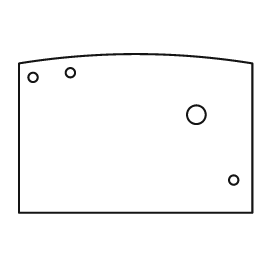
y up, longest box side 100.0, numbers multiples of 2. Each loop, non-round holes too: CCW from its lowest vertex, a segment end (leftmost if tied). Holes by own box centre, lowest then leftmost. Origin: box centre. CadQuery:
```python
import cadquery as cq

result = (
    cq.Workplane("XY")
    .moveTo(-50.0, -34.0)
    .lineTo(50.0, -34.0)
    .lineTo(50.0, 30.0)
    .threePointArc((0.0, 34.0), (-50.0, 30.0))
    .close()
    .moveTo(42.0, -20.0)
    .circle(2.0)
    .moveTo(26.0, 8.0)
    .circle(4.0)
    .moveTo(-44.0, 24.0)
    .circle(2.0)
    .moveTo(-28.0, 26.0)
    .circle(2.0)
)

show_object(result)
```